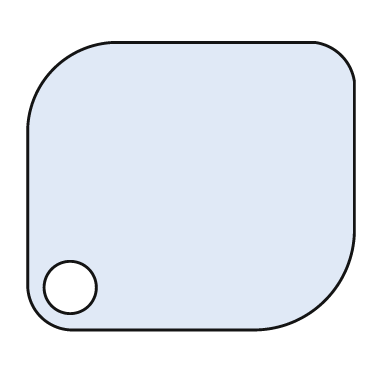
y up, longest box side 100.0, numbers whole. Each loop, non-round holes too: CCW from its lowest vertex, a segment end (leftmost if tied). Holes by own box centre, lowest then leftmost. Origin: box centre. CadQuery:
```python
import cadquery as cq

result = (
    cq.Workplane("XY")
    .moveTo(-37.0, -44.0)
    .lineTo(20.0, -44.0)
    .threePointArc((41.0, -35.0), (50.0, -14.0))
    .lineTo(50.0, 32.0)
    .threePointArc((46.0, 40.0), (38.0, 44.0))
    .lineTo(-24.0, 44.0)
    .threePointArc((-42.0, 36.0), (-50.0, 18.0))
    .lineTo(-50.0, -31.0)
    .threePointArc((-46.0, -40.0), (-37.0, -44.0))
    .close()
    .moveTo(-37.0, -31.0)
    .circle(8.0)
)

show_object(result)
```